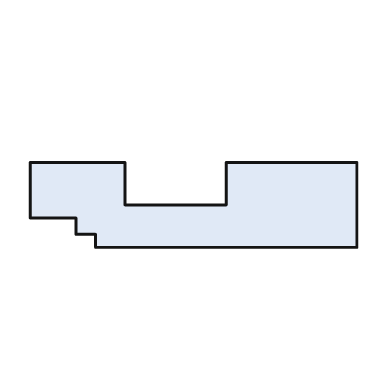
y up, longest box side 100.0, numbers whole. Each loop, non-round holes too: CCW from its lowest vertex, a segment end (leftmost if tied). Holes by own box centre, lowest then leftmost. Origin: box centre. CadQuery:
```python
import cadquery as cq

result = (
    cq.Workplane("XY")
    .moveTo(-30.0, -13.0)
    .lineTo(50.0, -13.0)
    .lineTo(50.0, 13.0)
    .lineTo(10.0, 13.0)
    .lineTo(10.0, 0.0)
    .lineTo(-21.0, 0.0)
    .lineTo(-21.0, 13.0)
    .lineTo(-50.0, 13.0)
    .lineTo(-50.0, -4.0)
    .lineTo(-36.0, -4.0)
    .lineTo(-36.0, -9.0)
    .lineTo(-30.0, -9.0)
    .close()
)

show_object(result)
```